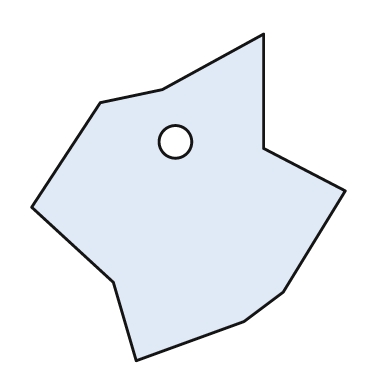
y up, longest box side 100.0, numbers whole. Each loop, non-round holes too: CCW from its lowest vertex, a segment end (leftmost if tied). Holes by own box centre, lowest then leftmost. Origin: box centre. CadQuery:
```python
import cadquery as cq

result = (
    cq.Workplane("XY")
    .moveTo(-16.0, -50.0)
    .lineTo(17.0, -38.0)
    .lineTo(29.0, -29.0)
    .lineTo(48.0, 2.0)
    .lineTo(23.0, 15.0)
    .lineTo(23.0, 50.0)
    .lineTo(-8.0, 33.0)
    .lineTo(-27.0, 29.0)
    .lineTo(-48.0, -3.0)
    .lineTo(-23.0, -26.0)
    .close()
    .moveTo(-4.0, 17.0)
    .circle(5.0)
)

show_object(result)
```